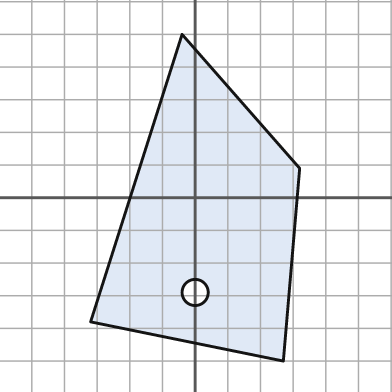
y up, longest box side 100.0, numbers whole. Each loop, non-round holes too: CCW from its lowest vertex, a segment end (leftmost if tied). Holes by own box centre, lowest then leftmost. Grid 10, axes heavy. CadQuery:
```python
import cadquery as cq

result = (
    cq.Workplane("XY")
    .moveTo(27.0, -50.0)
    .lineTo(32.0, 9.0)
    .lineTo(-4.0, 50.0)
    .lineTo(-32.0, -38.0)
    .close()
    .moveTo(0.0, -29.0)
    .circle(4.0)
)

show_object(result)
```